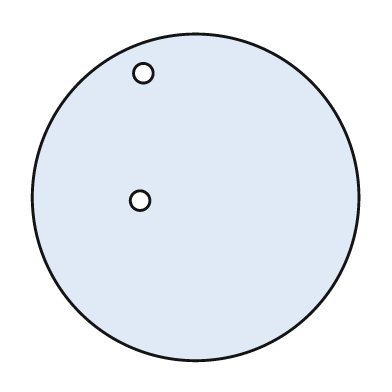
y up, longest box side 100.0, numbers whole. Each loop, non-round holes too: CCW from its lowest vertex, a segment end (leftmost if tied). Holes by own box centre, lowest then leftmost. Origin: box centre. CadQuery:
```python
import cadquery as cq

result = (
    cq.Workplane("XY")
    .moveTo(0.0, 0.0)
    .circle(50.0)
    .moveTo(-17.0, -1.0)
    .circle(3.0)
    .moveTo(-16.0, 38.0)
    .circle(3.0)
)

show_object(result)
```